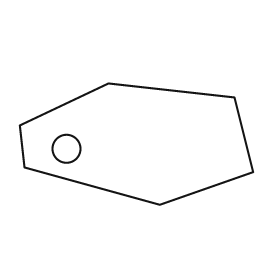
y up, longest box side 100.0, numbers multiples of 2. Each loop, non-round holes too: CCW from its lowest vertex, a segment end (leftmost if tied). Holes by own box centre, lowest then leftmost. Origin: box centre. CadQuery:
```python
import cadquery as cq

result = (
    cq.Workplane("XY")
    .moveTo(10.0, -26.0)
    .lineTo(50.0, -12.0)
    .lineTo(42.0, 20.0)
    .lineTo(-12.0, 26.0)
    .lineTo(-50.0, 8.0)
    .lineTo(-48.0, -10.0)
    .close()
    .moveTo(-30.0, -2.0)
    .circle(6.0)
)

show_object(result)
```